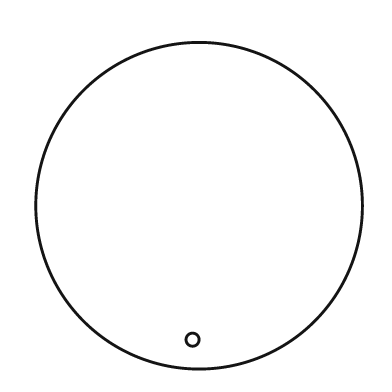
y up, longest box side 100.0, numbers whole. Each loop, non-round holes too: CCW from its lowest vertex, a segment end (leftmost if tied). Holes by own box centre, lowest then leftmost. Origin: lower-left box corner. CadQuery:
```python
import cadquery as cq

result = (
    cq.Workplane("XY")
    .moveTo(50.0, 50.0)
    .circle(50.0)
    .moveTo(48.0, 9.0)
    .circle(2.0)
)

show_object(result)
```